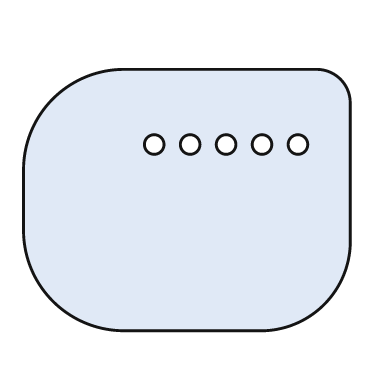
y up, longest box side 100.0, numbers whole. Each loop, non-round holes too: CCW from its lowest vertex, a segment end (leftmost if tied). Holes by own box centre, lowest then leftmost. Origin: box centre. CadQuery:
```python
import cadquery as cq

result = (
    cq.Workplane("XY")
    .moveTo(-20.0, -40.0)
    .lineTo(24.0, -40.0)
    .threePointArc((42.0, -32.0), (50.0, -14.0))
    .lineTo(50.0, 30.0)
    .threePointArc((47.0, 37.0), (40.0, 40.0))
    .lineTo(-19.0, 40.0)
    .threePointArc((-41.0, 31.0), (-50.0, 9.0))
    .lineTo(-50.0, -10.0)
    .threePointArc((-41.0, -31.0), (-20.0, -40.0))
    .close()
    .moveTo(-10.0, 17.0)
    .circle(3.0)
    .moveTo(1.0, 17.0)
    .circle(3.0)
    .moveTo(12.0, 17.0)
    .circle(3.0)
    .moveTo(23.0, 17.0)
    .circle(3.0)
    .moveTo(34.0, 17.0)
    .circle(3.0)
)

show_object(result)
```